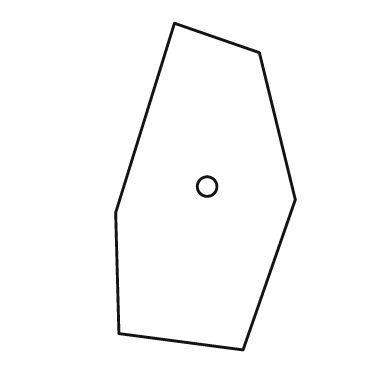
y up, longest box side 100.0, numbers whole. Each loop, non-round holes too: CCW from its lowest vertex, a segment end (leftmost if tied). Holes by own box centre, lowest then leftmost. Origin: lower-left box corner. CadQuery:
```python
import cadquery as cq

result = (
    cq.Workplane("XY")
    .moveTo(39.0, 0.0)
    .lineTo(55.0, 46.0)
    .lineTo(44.0, 91.0)
    .lineTo(18.0, 100.0)
    .lineTo(0.0, 42.0)
    .lineTo(1.0, 5.0)
    .close()
    .moveTo(28.0, 50.0)
    .circle(3.0)
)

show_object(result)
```